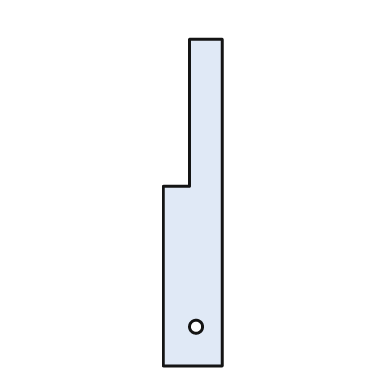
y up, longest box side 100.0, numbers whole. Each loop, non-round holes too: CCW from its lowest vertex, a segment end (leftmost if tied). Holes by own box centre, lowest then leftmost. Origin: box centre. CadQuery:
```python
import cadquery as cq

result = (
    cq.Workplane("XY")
    .moveTo(-9.0, -50.0)
    .lineTo(9.0, -50.0)
    .lineTo(9.0, 50.0)
    .lineTo(-1.0, 50.0)
    .lineTo(-1.0, 5.0)
    .lineTo(-9.0, 5.0)
    .close()
    .moveTo(1.0, -38.0)
    .circle(2.0)
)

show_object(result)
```